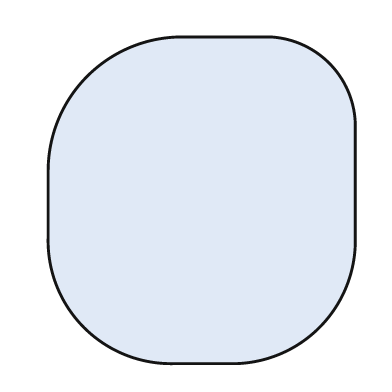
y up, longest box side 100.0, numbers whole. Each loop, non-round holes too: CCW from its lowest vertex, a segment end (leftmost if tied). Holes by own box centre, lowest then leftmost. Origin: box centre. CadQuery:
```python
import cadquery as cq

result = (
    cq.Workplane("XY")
    .moveTo(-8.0, -50.0)
    .lineTo(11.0, -50.0)
    .threePointArc((36.0, -39.0), (47.0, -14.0))
    .lineTo(47.0, 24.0)
    .threePointArc((39.0, 42.0), (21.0, 50.0))
    .lineTo(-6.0, 50.0)
    .threePointArc((-35.0, 38.0), (-47.0, 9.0))
    .lineTo(-47.0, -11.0)
    .threePointArc((-36.0, -39.0), (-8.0, -50.0))
    .close()
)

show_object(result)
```